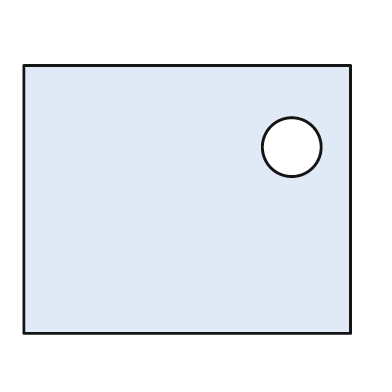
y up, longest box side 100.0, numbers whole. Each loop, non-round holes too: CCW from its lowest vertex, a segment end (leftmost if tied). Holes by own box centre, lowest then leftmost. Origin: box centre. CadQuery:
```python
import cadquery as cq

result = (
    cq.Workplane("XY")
    .moveTo(-50.0, -41.0)
    .lineTo(50.0, -41.0)
    .lineTo(50.0, 41.0)
    .lineTo(-50.0, 41.0)
    .close()
    .moveTo(32.0, 16.0)
    .circle(9.0)
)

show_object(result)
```